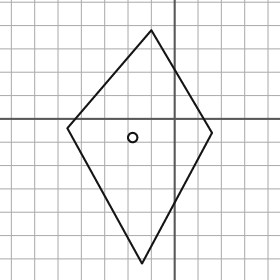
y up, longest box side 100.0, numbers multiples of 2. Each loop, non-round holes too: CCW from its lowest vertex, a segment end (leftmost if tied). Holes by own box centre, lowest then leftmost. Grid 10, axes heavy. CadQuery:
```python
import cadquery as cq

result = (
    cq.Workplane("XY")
    .moveTo(-14.0, -62.0)
    .lineTo(16.0, -6.0)
    .lineTo(-10.0, 38.0)
    .lineTo(-46.0, -4.0)
    .close()
    .moveTo(-18.0, -8.0)
    .circle(2.0)
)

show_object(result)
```